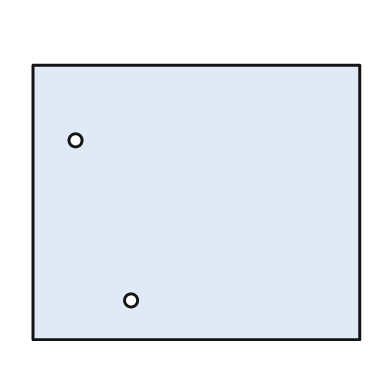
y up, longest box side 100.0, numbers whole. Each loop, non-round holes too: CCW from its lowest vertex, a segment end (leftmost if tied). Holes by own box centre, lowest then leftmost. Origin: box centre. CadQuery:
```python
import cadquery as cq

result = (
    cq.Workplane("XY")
    .moveTo(-50.0, -42.0)
    .lineTo(50.0, -42.0)
    .lineTo(50.0, 42.0)
    .lineTo(-50.0, 42.0)
    .close()
    .moveTo(-20.0, -30.0)
    .circle(2.0)
    .moveTo(-37.0, 19.0)
    .circle(2.0)
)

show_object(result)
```